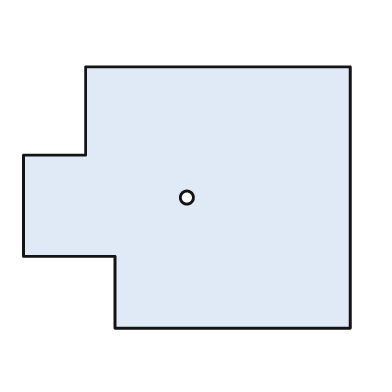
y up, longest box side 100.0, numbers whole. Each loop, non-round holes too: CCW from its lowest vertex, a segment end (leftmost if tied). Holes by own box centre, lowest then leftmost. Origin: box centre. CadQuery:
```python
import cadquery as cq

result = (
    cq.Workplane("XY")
    .moveTo(-22.0, -40.0)
    .lineTo(50.0, -40.0)
    .lineTo(50.0, 40.0)
    .lineTo(-31.0, 40.0)
    .lineTo(-31.0, 13.0)
    .lineTo(-50.0, 13.0)
    .lineTo(-50.0, -18.0)
    .lineTo(-22.0, -18.0)
    .close()
    .moveTo(0.0, 0.0)
    .circle(2.0)
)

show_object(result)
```